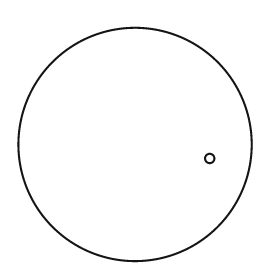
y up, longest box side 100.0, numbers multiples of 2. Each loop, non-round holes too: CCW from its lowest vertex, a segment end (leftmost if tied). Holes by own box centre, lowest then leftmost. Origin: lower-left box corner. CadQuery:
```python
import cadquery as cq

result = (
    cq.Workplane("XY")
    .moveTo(50.0, 50.0)
    .circle(50.0)
    .moveTo(82.0, 44.0)
    .circle(2.0)
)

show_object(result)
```